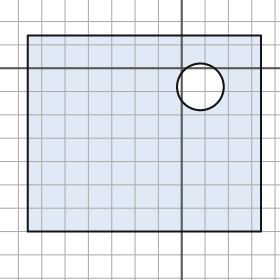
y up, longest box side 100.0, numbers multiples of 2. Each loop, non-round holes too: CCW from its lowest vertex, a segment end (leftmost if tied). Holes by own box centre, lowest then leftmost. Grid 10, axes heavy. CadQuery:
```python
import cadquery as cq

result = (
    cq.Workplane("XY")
    .moveTo(-66.0, -70.0)
    .lineTo(34.0, -70.0)
    .lineTo(34.0, 14.0)
    .lineTo(-66.0, 14.0)
    .close()
    .moveTo(8.0, -8.0)
    .circle(10.0)
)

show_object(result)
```